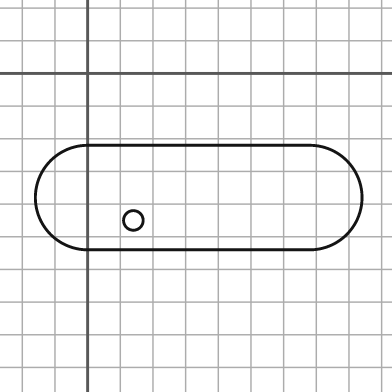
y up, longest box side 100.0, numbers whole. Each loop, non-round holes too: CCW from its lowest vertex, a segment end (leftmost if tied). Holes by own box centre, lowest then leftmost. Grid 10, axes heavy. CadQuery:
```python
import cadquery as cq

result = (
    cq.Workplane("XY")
    .moveTo(0.0, -54.0)
    .lineTo(68.0, -54.0)
    .threePointArc((84.0, -38.0), (68.0, -22.0))
    .lineTo(0.0, -22.0)
    .threePointArc((-16.0, -38.0), (0.0, -54.0))
    .close()
    .moveTo(14.0, -45.0)
    .circle(3.0)
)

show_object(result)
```